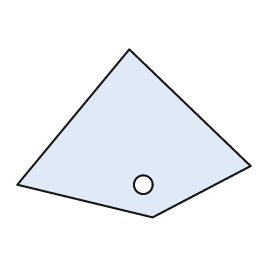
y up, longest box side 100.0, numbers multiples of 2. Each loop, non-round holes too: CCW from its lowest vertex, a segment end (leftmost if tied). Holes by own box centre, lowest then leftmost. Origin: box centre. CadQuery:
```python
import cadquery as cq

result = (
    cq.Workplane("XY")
    .moveTo(8.0, -36.0)
    .lineTo(50.0, -14.0)
    .lineTo(-2.0, 36.0)
    .lineTo(-50.0, -22.0)
    .close()
    .moveTo(4.0, -22.0)
    .circle(4.0)
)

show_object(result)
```